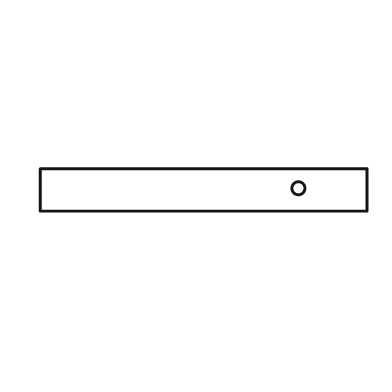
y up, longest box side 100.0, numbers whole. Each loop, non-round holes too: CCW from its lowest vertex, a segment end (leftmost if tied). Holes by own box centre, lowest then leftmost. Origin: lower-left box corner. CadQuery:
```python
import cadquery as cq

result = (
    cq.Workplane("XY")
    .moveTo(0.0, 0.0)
    .lineTo(100.0, 0.0)
    .lineTo(100.0, 13.0)
    .lineTo(0.0, 13.0)
    .close()
    .moveTo(79.0, 7.0)
    .circle(2.0)
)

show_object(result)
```